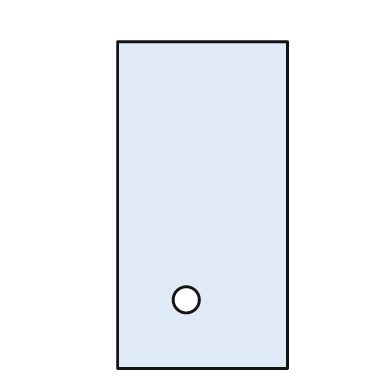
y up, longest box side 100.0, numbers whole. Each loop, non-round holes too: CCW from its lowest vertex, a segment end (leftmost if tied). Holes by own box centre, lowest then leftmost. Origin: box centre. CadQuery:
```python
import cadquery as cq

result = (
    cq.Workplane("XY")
    .moveTo(-26.0, -50.0)
    .lineTo(26.0, -50.0)
    .lineTo(26.0, 50.0)
    .lineTo(-26.0, 50.0)
    .close()
    .moveTo(-5.0, -29.0)
    .circle(4.0)
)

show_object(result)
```